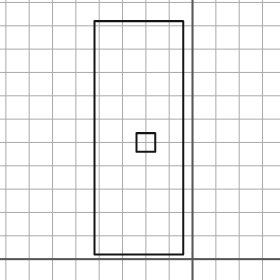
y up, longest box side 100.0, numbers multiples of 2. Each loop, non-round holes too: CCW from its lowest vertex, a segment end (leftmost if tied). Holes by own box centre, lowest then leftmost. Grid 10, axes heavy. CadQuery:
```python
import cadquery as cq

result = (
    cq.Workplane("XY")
    .moveTo(-42.0, 2.0)
    .lineTo(-4.0, 2.0)
    .lineTo(-4.0, 102.0)
    .lineTo(-42.0, 102.0)
    .close()
    .moveTo(-24.0, 46.0)
    .lineTo(-16.0, 46.0)
    .lineTo(-16.0, 54.0)
    .lineTo(-24.0, 54.0)
    .close()
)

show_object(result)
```